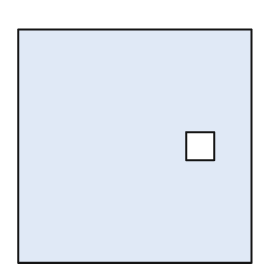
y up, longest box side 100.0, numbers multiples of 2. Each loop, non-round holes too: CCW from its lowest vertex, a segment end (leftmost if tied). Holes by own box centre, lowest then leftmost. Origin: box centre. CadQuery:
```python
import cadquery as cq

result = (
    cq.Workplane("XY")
    .moveTo(-50.0, -50.0)
    .lineTo(50.0, -50.0)
    .lineTo(50.0, 50.0)
    .lineTo(-50.0, 50.0)
    .close()
    .moveTo(22.0, -6.0)
    .lineTo(34.0, -6.0)
    .lineTo(34.0, 6.0)
    .lineTo(22.0, 6.0)
    .close()
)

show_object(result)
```